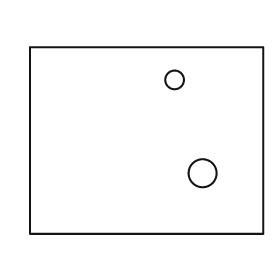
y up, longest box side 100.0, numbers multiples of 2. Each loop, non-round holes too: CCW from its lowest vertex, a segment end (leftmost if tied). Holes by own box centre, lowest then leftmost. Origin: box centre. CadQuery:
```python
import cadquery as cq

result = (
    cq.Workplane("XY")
    .moveTo(-50.0, -40.0)
    .lineTo(50.0, -40.0)
    .lineTo(50.0, 40.0)
    .lineTo(-50.0, 40.0)
    .close()
    .moveTo(24.0, -14.0)
    .circle(6.0)
    .moveTo(12.0, 26.0)
    .circle(4.0)
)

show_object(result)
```